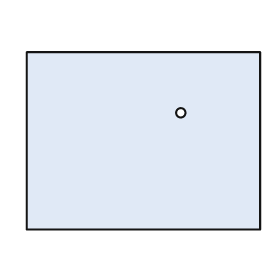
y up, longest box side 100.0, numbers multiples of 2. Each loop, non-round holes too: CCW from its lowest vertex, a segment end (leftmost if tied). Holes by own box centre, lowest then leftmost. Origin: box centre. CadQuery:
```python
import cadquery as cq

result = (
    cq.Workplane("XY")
    .moveTo(-50.0, -38.0)
    .lineTo(50.0, -38.0)
    .lineTo(50.0, 38.0)
    .lineTo(-50.0, 38.0)
    .close()
    .moveTo(16.0, 12.0)
    .circle(2.0)
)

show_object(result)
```